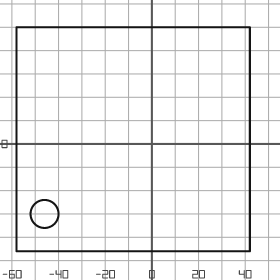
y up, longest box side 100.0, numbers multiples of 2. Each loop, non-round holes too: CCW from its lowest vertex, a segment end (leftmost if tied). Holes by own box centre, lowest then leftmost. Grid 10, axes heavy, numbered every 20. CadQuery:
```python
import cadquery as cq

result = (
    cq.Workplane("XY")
    .moveTo(-58.0, -46.0)
    .lineTo(42.0, -46.0)
    .lineTo(42.0, 50.0)
    .lineTo(-58.0, 50.0)
    .close()
    .moveTo(-46.0, -30.0)
    .circle(6.0)
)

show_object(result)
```